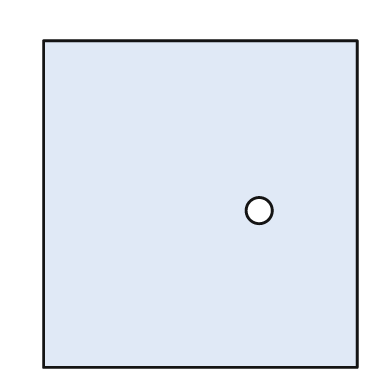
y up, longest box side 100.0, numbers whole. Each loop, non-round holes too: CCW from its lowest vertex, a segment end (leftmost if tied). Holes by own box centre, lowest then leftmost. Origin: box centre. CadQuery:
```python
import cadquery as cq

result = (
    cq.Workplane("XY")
    .moveTo(-48.0, -50.0)
    .lineTo(48.0, -50.0)
    .lineTo(48.0, 50.0)
    .lineTo(-48.0, 50.0)
    .close()
    .moveTo(18.0, -2.0)
    .circle(4.0)
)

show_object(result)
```